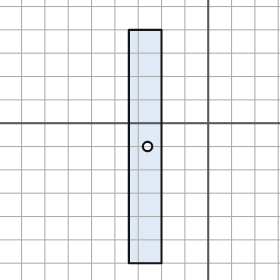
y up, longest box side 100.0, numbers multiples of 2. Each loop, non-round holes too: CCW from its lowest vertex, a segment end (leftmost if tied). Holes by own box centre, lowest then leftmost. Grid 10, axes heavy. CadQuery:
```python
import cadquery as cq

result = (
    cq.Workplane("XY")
    .moveTo(-34.0, -60.0)
    .lineTo(-20.0, -60.0)
    .lineTo(-20.0, 40.0)
    .lineTo(-34.0, 40.0)
    .close()
    .moveTo(-26.0, -10.0)
    .circle(2.0)
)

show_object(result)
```